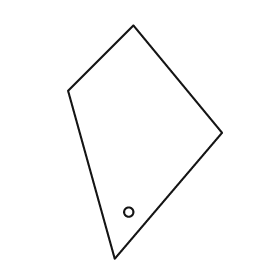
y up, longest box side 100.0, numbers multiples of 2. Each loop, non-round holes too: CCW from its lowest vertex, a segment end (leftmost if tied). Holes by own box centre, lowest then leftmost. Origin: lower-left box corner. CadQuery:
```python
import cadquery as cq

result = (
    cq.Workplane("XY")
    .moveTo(20.0, 0.0)
    .lineTo(66.0, 54.0)
    .lineTo(28.0, 100.0)
    .lineTo(0.0, 72.0)
    .close()
    .moveTo(26.0, 20.0)
    .circle(2.0)
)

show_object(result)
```